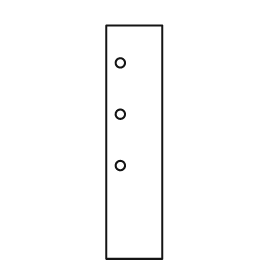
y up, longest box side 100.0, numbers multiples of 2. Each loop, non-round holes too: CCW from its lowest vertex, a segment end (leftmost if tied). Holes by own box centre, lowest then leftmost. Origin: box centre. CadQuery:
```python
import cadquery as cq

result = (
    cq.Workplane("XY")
    .moveTo(-12.0, -50.0)
    .lineTo(12.0, -50.0)
    .lineTo(12.0, 50.0)
    .lineTo(-12.0, 50.0)
    .close()
    .moveTo(-6.0, -10.0)
    .circle(2.0)
    .moveTo(-6.0, 12.0)
    .circle(2.0)
    .moveTo(-6.0, 34.0)
    .circle(2.0)
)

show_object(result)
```